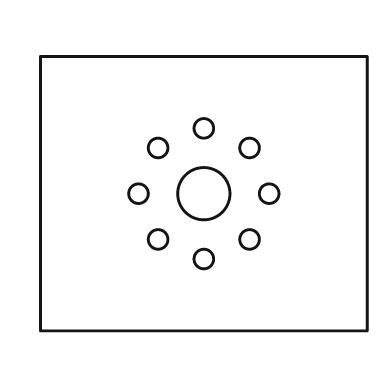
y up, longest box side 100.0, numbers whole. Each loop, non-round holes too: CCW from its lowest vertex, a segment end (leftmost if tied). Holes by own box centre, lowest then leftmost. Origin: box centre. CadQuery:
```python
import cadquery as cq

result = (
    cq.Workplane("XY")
    .moveTo(-50.0, -42.0)
    .lineTo(50.0, -42.0)
    .lineTo(50.0, 42.0)
    .lineTo(-50.0, 42.0)
    .close()
    .moveTo(0.0, -20.0)
    .circle(3.0)
    .moveTo(-14.0, -14.0)
    .circle(3.0)
    .moveTo(14.0, -14.0)
    .circle(3.0)
    .moveTo(-20.0, 0.0)
    .circle(3.0)
    .moveTo(0.0, 0.0)
    .circle(8.0)
    .moveTo(20.0, 0.0)
    .circle(3.0)
    .moveTo(-14.0, 14.0)
    .circle(3.0)
    .moveTo(14.0, 14.0)
    .circle(3.0)
    .moveTo(0.0, 20.0)
    .circle(3.0)
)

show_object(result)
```